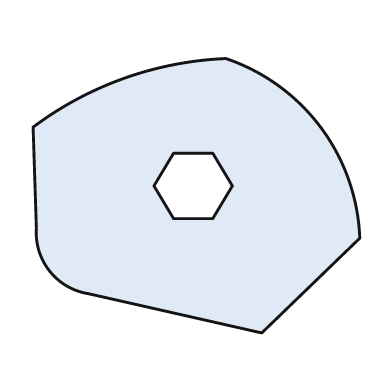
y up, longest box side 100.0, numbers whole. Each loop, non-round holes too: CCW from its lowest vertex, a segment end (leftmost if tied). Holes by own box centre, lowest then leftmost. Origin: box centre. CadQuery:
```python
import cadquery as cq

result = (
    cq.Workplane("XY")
    .moveTo(20.0, -42.0)
    .lineTo(50.0, -13.0)
    .threePointArc((38.0, 21.0), (9.0, 42.0))
    .threePointArc((-22.0, 36.0), (-50.0, 21.0))
    .lineTo(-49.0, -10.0)
    .threePointArc((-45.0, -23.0), (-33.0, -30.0))
    .close()
    .moveTo(-7.0, -7.0)
    .lineTo(5.0, -7.0)
    .lineTo(11.0, 3.0)
    .lineTo(5.0, 13.0)
    .lineTo(-7.0, 13.0)
    .lineTo(-13.0, 3.0)
    .close()
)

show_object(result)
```